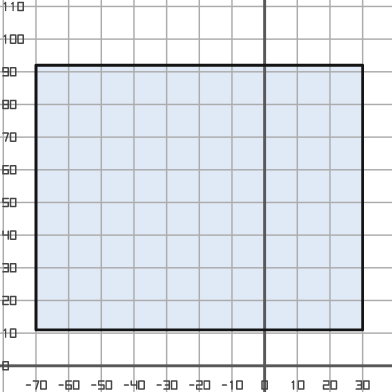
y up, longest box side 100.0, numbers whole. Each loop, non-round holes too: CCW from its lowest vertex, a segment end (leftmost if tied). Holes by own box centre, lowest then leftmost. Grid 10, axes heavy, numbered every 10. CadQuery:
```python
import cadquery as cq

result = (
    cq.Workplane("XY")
    .moveTo(-70.0, 11.0)
    .lineTo(30.0, 11.0)
    .lineTo(30.0, 92.0)
    .lineTo(-70.0, 92.0)
    .close()
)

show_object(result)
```